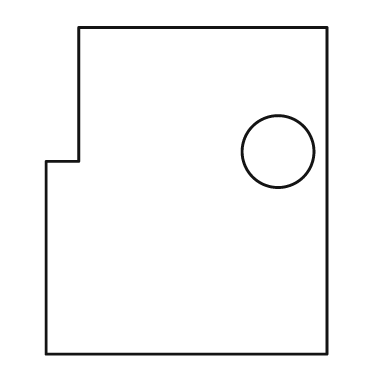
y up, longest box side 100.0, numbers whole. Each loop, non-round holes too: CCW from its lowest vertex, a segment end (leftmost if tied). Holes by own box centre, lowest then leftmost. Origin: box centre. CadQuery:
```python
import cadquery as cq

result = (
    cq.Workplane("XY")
    .moveTo(-43.0, -50.0)
    .lineTo(43.0, -50.0)
    .lineTo(43.0, 50.0)
    .lineTo(-33.0, 50.0)
    .lineTo(-33.0, 9.0)
    .lineTo(-43.0, 9.0)
    .close()
    .moveTo(28.0, 12.0)
    .circle(11.0)
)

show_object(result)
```